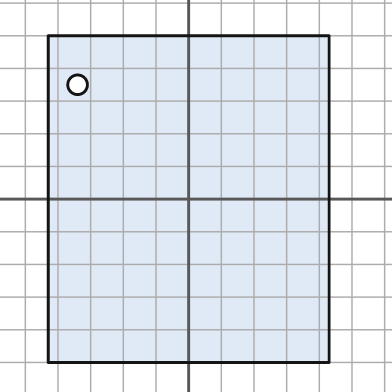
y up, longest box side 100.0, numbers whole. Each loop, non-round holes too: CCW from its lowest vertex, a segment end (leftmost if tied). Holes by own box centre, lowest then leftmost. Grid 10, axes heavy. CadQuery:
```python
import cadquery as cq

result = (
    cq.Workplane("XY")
    .moveTo(-43.0, -50.0)
    .lineTo(43.0, -50.0)
    .lineTo(43.0, 50.0)
    .lineTo(-43.0, 50.0)
    .close()
    .moveTo(-34.0, 35.0)
    .circle(3.0)
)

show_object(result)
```